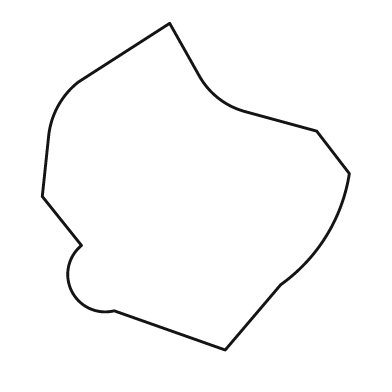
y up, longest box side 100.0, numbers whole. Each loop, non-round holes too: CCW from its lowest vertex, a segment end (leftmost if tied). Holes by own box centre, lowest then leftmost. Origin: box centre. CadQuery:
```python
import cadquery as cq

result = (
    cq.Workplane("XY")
    .moveTo(9.0, -50.0)
    .lineTo(26.0, -30.0)
    .threePointArc((40.0, -15.0), (47.0, 4.0))
    .lineTo(37.0, 17.0)
    .lineTo(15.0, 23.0)
    .threePointArc((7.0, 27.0), (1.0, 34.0))
    .lineTo(-8.0, 50.0)
    .lineTo(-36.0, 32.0)
    .threePointArc((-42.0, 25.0), (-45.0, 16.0))
    .lineTo(-47.0, -3.0)
    .lineTo(-35.0, -18.0)
    .threePointArc((-38.0, -32.0), (-25.0, -38.0))
    .close()
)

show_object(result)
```